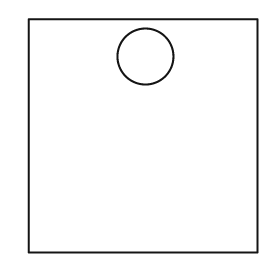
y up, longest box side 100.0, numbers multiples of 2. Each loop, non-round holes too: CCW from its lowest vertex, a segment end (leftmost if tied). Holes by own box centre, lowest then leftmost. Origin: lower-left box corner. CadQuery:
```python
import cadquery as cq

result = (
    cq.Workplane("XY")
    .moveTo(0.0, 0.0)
    .lineTo(98.0, 0.0)
    .lineTo(98.0, 100.0)
    .lineTo(0.0, 100.0)
    .close()
    .moveTo(50.0, 84.0)
    .circle(12.0)
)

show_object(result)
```